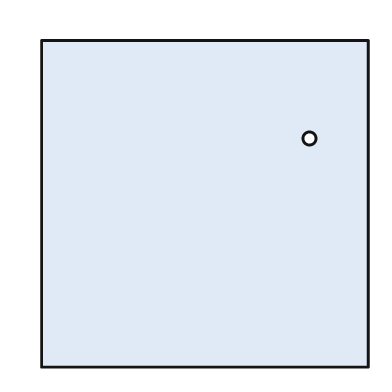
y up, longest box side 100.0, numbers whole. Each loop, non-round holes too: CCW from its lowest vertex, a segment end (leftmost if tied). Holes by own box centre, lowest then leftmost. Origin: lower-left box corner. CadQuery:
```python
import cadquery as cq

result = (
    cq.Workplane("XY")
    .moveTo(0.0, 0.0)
    .lineTo(100.0, 0.0)
    .lineTo(100.0, 100.0)
    .lineTo(0.0, 100.0)
    .close()
    .moveTo(82.0, 70.0)
    .circle(2.0)
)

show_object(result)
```